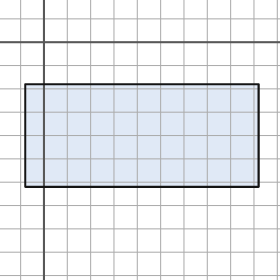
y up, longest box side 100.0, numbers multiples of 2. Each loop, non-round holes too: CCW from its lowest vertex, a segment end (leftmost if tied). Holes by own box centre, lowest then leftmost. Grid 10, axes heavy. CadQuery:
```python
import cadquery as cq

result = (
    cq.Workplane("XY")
    .moveTo(-8.0, -62.0)
    .lineTo(92.0, -62.0)
    .lineTo(92.0, -18.0)
    .lineTo(-8.0, -18.0)
    .close()
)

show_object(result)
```